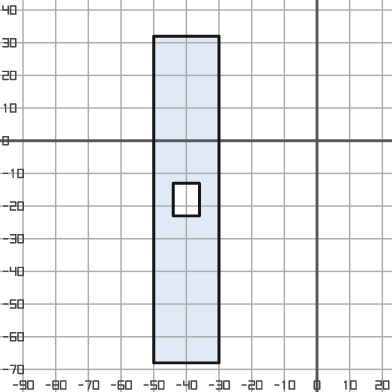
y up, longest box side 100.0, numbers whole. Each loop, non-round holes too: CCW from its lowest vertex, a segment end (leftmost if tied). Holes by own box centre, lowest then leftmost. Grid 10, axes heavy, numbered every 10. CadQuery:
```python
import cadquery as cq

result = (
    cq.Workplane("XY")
    .moveTo(-50.0, -68.0)
    .lineTo(-30.0, -68.0)
    .lineTo(-30.0, 32.0)
    .lineTo(-50.0, 32.0)
    .close()
    .moveTo(-44.0, -23.0)
    .lineTo(-36.0, -23.0)
    .lineTo(-36.0, -13.0)
    .lineTo(-44.0, -13.0)
    .close()
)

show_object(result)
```